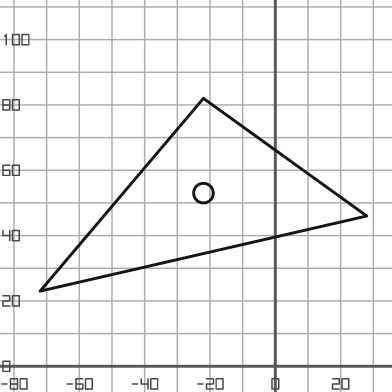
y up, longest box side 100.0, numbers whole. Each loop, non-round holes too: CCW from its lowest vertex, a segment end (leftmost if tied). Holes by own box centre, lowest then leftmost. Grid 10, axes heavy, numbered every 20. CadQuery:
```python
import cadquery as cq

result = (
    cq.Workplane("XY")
    .moveTo(-72.0, 23.0)
    .lineTo(28.0, 46.0)
    .lineTo(-22.0, 82.0)
    .close()
    .moveTo(-22.0, 53.0)
    .circle(3.0)
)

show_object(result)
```